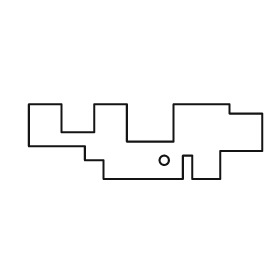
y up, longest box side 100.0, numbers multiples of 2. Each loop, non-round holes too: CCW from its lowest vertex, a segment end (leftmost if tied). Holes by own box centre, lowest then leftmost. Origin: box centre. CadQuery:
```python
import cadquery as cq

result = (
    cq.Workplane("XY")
    .moveTo(-18.0, -16.0)
    .lineTo(16.0, -16.0)
    .lineTo(16.0, -6.0)
    .lineTo(20.0, -6.0)
    .lineTo(20.0, -16.0)
    .lineTo(32.0, -16.0)
    .lineTo(32.0, -4.0)
    .lineTo(50.0, -4.0)
    .lineTo(50.0, 12.0)
    .lineTo(36.0, 12.0)
    .lineTo(36.0, 16.0)
    .lineTo(12.0, 16.0)
    .lineTo(12.0, 0.0)
    .lineTo(-8.0, 0.0)
    .lineTo(-8.0, 16.0)
    .lineTo(-22.0, 16.0)
    .lineTo(-22.0, 4.0)
    .lineTo(-36.0, 4.0)
    .lineTo(-36.0, 16.0)
    .lineTo(-50.0, 16.0)
    .lineTo(-50.0, -2.0)
    .lineTo(-26.0, -2.0)
    .lineTo(-26.0, -8.0)
    .lineTo(-18.0, -8.0)
    .close()
    .moveTo(8.0, -8.0)
    .circle(2.0)
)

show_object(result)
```